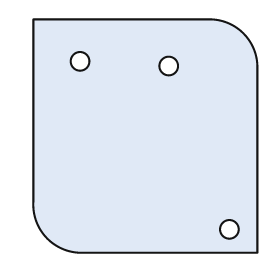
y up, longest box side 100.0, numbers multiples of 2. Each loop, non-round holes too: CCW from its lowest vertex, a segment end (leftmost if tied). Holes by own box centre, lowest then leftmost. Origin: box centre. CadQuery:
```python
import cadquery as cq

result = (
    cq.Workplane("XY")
    .moveTo(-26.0, -50.0)
    .lineTo(48.0, -50.0)
    .lineTo(48.0, 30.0)
    .threePointArc((42.0, 44.0), (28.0, 50.0))
    .lineTo(-48.0, 50.0)
    .lineTo(-48.0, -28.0)
    .threePointArc((-42.0, -44.0), (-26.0, -50.0))
    .close()
    .moveTo(36.0, -40.0)
    .circle(4.0)
    .moveTo(10.0, 30.0)
    .circle(4.0)
    .moveTo(-28.0, 32.0)
    .circle(4.0)
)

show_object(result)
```